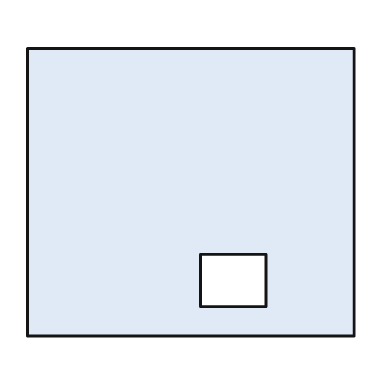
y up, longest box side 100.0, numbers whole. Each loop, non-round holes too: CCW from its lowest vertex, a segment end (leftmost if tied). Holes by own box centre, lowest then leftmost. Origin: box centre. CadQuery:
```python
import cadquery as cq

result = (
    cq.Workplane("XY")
    .moveTo(-50.0, -44.0)
    .lineTo(50.0, -44.0)
    .lineTo(50.0, 44.0)
    .lineTo(-50.0, 44.0)
    .close()
    .moveTo(3.0, -35.0)
    .lineTo(23.0, -35.0)
    .lineTo(23.0, -19.0)
    .lineTo(3.0, -19.0)
    .close()
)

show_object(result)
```